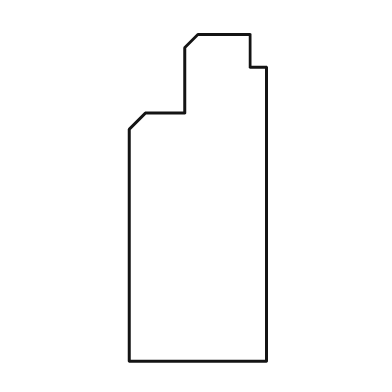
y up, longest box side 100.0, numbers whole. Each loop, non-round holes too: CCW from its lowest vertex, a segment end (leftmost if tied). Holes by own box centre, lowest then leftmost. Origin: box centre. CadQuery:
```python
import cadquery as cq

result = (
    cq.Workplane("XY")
    .moveTo(-21.0, -50.0)
    .lineTo(21.0, -50.0)
    .lineTo(21.0, 40.0)
    .lineTo(16.0, 40.0)
    .lineTo(16.0, 50.0)
    .lineTo(0.0, 50.0)
    .lineTo(-4.0, 46.0)
    .lineTo(-4.0, 26.0)
    .lineTo(-16.0, 26.0)
    .lineTo(-21.0, 21.0)
    .close()
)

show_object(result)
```